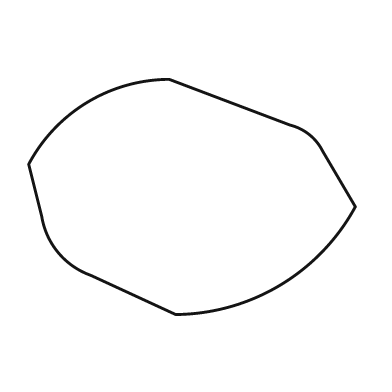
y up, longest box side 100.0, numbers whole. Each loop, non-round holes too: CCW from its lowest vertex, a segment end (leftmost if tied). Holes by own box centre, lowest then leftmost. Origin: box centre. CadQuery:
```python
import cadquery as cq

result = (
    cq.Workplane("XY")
    .moveTo(-5.0, -36.0)
    .threePointArc((27.0, -27.0), (50.0, -3.0))
    .lineTo(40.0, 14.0)
    .threePointArc((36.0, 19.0), (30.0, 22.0))
    .lineTo(-7.0, 36.0)
    .threePointArc((-32.0, 29.0), (-50.0, 10.0))
    .lineTo(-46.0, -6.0)
    .threePointArc((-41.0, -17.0), (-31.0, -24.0))
    .close()
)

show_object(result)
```